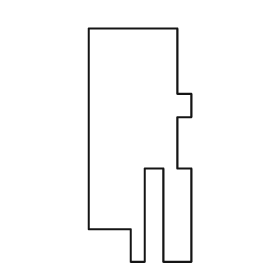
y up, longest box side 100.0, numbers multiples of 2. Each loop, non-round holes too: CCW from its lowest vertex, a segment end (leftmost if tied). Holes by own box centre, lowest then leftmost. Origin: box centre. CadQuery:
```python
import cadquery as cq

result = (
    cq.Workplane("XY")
    .moveTo(-4.0, -50.0)
    .lineTo(2.0, -50.0)
    .lineTo(2.0, -10.0)
    .lineTo(10.0, -10.0)
    .lineTo(10.0, -50.0)
    .lineTo(22.0, -50.0)
    .lineTo(22.0, -10.0)
    .lineTo(16.0, -10.0)
    .lineTo(16.0, 12.0)
    .lineTo(22.0, 12.0)
    .lineTo(22.0, 22.0)
    .lineTo(16.0, 22.0)
    .lineTo(16.0, 50.0)
    .lineTo(-22.0, 50.0)
    .lineTo(-22.0, -36.0)
    .lineTo(-4.0, -36.0)
    .close()
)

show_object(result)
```